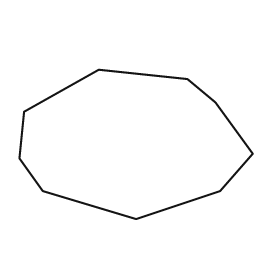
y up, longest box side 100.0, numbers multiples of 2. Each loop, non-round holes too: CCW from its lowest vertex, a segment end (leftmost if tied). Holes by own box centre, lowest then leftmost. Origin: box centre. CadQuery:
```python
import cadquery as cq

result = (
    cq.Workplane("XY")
    .moveTo(0.0, -32.0)
    .lineTo(36.0, -20.0)
    .lineTo(50.0, -4.0)
    .lineTo(34.0, 18.0)
    .lineTo(22.0, 28.0)
    .lineTo(-16.0, 32.0)
    .lineTo(-48.0, 14.0)
    .lineTo(-50.0, -6.0)
    .lineTo(-40.0, -20.0)
    .close()
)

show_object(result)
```